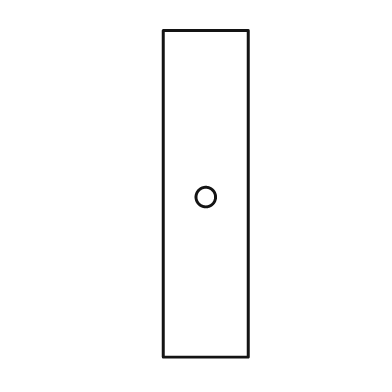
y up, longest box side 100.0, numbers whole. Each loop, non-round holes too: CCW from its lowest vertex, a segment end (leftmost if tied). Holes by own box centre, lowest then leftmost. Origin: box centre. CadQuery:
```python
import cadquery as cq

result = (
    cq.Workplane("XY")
    .moveTo(-13.0, -50.0)
    .lineTo(13.0, -50.0)
    .lineTo(13.0, 50.0)
    .lineTo(-13.0, 50.0)
    .close()
    .moveTo(0.0, -1.0)
    .circle(3.0)
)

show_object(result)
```